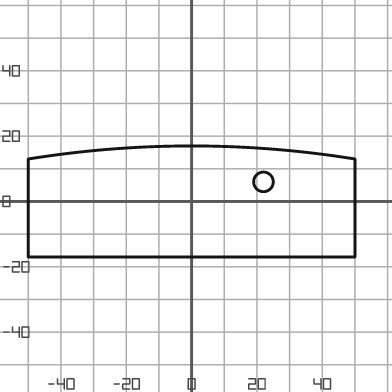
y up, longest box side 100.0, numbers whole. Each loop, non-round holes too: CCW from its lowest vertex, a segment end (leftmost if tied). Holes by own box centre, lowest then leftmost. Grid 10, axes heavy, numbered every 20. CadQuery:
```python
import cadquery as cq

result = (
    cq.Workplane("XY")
    .moveTo(-50.0, -17.0)
    .lineTo(50.0, -17.0)
    .lineTo(50.0, 13.0)
    .threePointArc((0.0, 17.0), (-50.0, 13.0))
    .close()
    .moveTo(22.0, 6.0)
    .circle(3.0)
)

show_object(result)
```